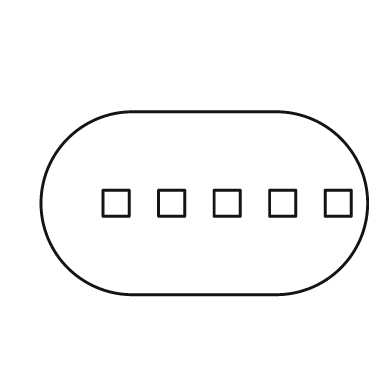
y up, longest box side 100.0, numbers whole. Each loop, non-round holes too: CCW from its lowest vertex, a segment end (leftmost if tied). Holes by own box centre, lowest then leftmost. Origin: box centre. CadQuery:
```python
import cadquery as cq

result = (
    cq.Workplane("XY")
    .moveTo(-22.0, -28.0)
    .lineTo(22.0, -28.0)
    .threePointArc((50.0, 0.0), (22.0, 28.0))
    .lineTo(-22.0, 28.0)
    .threePointArc((-50.0, 0.0), (-22.0, -28.0))
    .close()
    .moveTo(-31.0, -4.0)
    .lineTo(-23.0, -4.0)
    .lineTo(-23.0, 4.0)
    .lineTo(-31.0, 4.0)
    .close()
    .moveTo(-14.0, -4.0)
    .lineTo(-6.0, -4.0)
    .lineTo(-6.0, 4.0)
    .lineTo(-14.0, 4.0)
    .close()
    .moveTo(3.0, -4.0)
    .lineTo(11.0, -4.0)
    .lineTo(11.0, 4.0)
    .lineTo(3.0, 4.0)
    .close()
    .moveTo(20.0, -4.0)
    .lineTo(28.0, -4.0)
    .lineTo(28.0, 4.0)
    .lineTo(20.0, 4.0)
    .close()
    .moveTo(37.0, -4.0)
    .lineTo(45.0, -4.0)
    .lineTo(45.0, 4.0)
    .lineTo(37.0, 4.0)
    .close()
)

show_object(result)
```